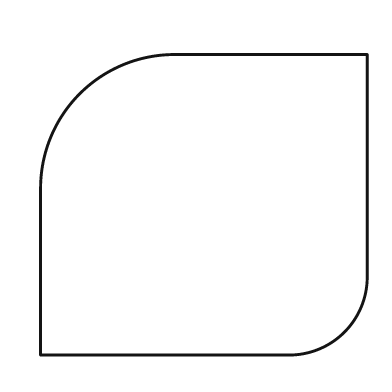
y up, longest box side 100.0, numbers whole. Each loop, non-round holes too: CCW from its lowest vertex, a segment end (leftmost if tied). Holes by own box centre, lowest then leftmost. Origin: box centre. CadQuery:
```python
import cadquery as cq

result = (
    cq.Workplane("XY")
    .moveTo(-50.0, -46.0)
    .lineTo(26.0, -46.0)
    .threePointArc((43.0, -39.0), (50.0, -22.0))
    .lineTo(50.0, 46.0)
    .lineTo(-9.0, 46.0)
    .threePointArc((-38.0, 34.0), (-50.0, 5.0))
    .close()
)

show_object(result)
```